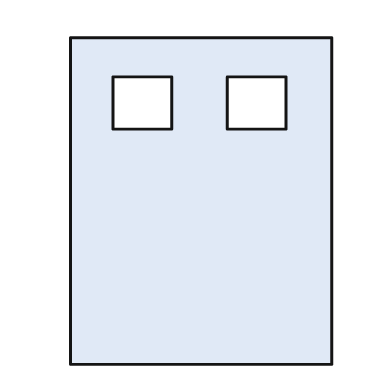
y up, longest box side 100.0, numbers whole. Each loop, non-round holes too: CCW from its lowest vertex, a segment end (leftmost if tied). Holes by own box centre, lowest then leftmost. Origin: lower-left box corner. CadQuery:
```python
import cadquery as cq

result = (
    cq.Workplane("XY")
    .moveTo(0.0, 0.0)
    .lineTo(80.0, 0.0)
    .lineTo(80.0, 100.0)
    .lineTo(0.0, 100.0)
    .close()
    .moveTo(13.0, 72.0)
    .lineTo(31.0, 72.0)
    .lineTo(31.0, 88.0)
    .lineTo(13.0, 88.0)
    .close()
    .moveTo(48.0, 72.0)
    .lineTo(66.0, 72.0)
    .lineTo(66.0, 88.0)
    .lineTo(48.0, 88.0)
    .close()
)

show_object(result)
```